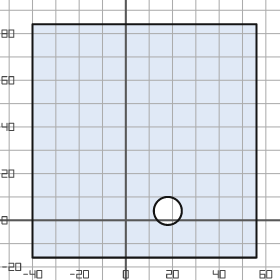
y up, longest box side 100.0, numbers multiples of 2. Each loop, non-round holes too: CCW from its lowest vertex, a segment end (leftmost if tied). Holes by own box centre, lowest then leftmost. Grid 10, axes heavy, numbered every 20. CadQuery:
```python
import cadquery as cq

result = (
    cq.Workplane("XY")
    .moveTo(-40.0, -16.0)
    .lineTo(56.0, -16.0)
    .lineTo(56.0, 84.0)
    .lineTo(-40.0, 84.0)
    .close()
    .moveTo(18.0, 4.0)
    .circle(6.0)
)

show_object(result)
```